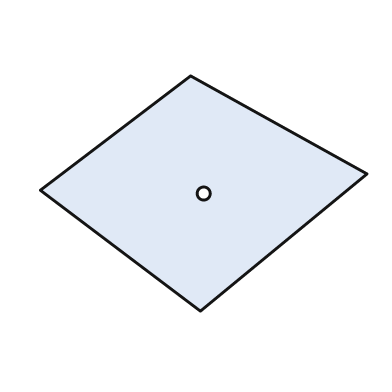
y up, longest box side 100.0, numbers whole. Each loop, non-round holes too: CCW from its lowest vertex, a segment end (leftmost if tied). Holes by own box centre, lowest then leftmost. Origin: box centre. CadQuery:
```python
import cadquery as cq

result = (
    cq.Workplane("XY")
    .moveTo(-1.0, -36.0)
    .lineTo(50.0, 6.0)
    .lineTo(-4.0, 36.0)
    .lineTo(-50.0, 1.0)
    .close()
    .moveTo(0.0, 0.0)
    .circle(2.0)
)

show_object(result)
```